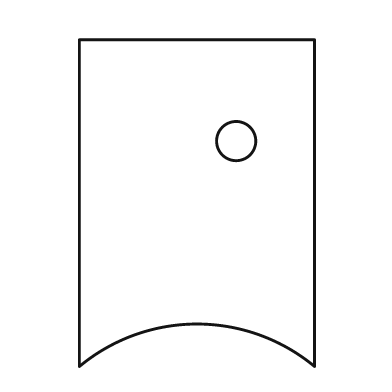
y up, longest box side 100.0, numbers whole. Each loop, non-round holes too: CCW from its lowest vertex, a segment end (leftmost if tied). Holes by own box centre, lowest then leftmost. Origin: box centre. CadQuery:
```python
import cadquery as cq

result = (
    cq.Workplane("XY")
    .moveTo(-36.0, -50.0)
    .threePointArc((0.0, -37.0), (36.0, -50.0))
    .lineTo(36.0, 50.0)
    .lineTo(-36.0, 50.0)
    .close()
    .moveTo(12.0, 19.0)
    .circle(6.0)
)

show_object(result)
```